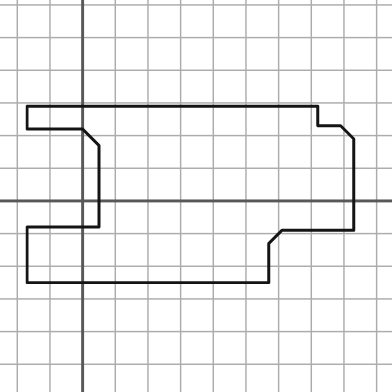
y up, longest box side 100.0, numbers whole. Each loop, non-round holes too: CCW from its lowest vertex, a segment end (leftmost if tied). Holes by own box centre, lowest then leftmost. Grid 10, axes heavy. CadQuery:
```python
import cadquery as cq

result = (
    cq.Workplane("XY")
    .moveTo(-17.0, -25.0)
    .lineTo(57.0, -25.0)
    .lineTo(57.0, -13.0)
    .lineTo(61.0, -9.0)
    .lineTo(83.0, -9.0)
    .lineTo(83.0, 19.0)
    .lineTo(79.0, 23.0)
    .lineTo(72.0, 23.0)
    .lineTo(72.0, 29.0)
    .lineTo(-17.0, 29.0)
    .lineTo(-17.0, 22.0)
    .lineTo(0.0, 22.0)
    .lineTo(5.0, 17.0)
    .lineTo(5.0, -8.0)
    .lineTo(-17.0, -8.0)
    .close()
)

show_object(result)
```